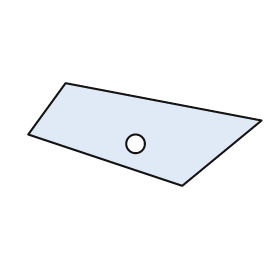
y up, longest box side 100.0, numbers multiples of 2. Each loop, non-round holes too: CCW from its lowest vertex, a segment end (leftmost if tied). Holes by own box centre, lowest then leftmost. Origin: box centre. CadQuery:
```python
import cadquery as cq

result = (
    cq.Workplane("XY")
    .moveTo(16.0, -22.0)
    .lineTo(50.0, 6.0)
    .lineTo(-34.0, 22.0)
    .lineTo(-50.0, 0.0)
    .close()
    .moveTo(-4.0, -4.0)
    .circle(4.0)
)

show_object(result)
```